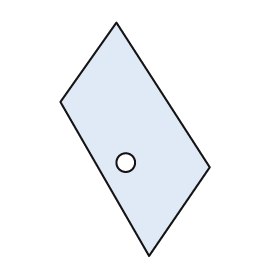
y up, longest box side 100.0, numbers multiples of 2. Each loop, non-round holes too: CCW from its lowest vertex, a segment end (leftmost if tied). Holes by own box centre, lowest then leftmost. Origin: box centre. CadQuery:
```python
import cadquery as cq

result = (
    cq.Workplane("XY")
    .moveTo(6.0, -50.0)
    .lineTo(32.0, -12.0)
    .lineTo(-8.0, 50.0)
    .lineTo(-32.0, 16.0)
    .close()
    .moveTo(-4.0, -10.0)
    .circle(4.0)
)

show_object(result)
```